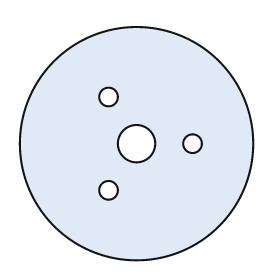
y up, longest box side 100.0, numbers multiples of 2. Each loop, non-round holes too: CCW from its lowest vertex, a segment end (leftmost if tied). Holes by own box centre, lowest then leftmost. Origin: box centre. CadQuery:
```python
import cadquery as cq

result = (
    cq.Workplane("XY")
    .moveTo(0.0, 0.0)
    .circle(50.0)
    .moveTo(-12.0, -20.0)
    .circle(4.0)
    .moveTo(0.0, 0.0)
    .circle(8.0)
    .moveTo(24.0, 0.0)
    .circle(4.0)
    .moveTo(-12.0, 20.0)
    .circle(4.0)
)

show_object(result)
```